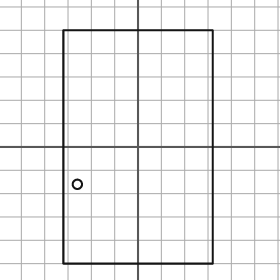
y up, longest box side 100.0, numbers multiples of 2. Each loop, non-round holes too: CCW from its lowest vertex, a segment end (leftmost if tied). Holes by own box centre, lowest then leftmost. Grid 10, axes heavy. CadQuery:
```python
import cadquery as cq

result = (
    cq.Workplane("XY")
    .moveTo(-32.0, -50.0)
    .lineTo(32.0, -50.0)
    .lineTo(32.0, 50.0)
    .lineTo(-32.0, 50.0)
    .close()
    .moveTo(-26.0, -16.0)
    .circle(2.0)
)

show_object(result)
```